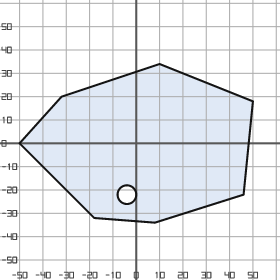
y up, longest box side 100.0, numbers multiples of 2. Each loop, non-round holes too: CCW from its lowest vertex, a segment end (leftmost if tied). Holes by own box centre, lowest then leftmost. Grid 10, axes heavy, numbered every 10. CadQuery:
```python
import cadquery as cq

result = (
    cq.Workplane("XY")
    .moveTo(8.0, -34.0)
    .lineTo(46.0, -22.0)
    .lineTo(50.0, 18.0)
    .lineTo(10.0, 34.0)
    .lineTo(-32.0, 20.0)
    .lineTo(-50.0, 0.0)
    .lineTo(-18.0, -32.0)
    .close()
    .moveTo(-4.0, -22.0)
    .circle(4.0)
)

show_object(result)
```